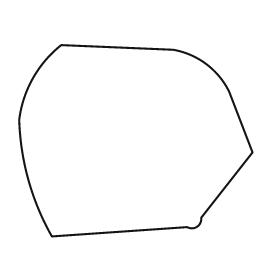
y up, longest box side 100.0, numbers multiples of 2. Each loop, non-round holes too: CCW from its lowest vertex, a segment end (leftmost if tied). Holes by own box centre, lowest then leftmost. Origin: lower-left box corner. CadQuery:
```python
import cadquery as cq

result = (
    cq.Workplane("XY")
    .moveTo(14.0, 0.0)
    .lineTo(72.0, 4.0)
    .threePointArc((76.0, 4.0), (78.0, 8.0))
    .lineTo(100.0, 36.0)
    .lineTo(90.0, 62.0)
    .threePointArc((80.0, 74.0), (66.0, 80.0))
    .lineTo(18.0, 82.0)
    .threePointArc((6.0, 68.0), (0.0, 50.0))
    .threePointArc((4.0, 24.0), (14.0, 0.0))
    .close()
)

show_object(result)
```